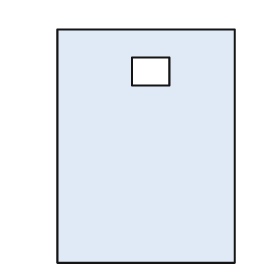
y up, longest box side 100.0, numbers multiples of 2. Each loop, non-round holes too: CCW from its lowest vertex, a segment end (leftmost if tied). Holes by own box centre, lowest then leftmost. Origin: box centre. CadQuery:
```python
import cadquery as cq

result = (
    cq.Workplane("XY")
    .moveTo(-38.0, -50.0)
    .lineTo(38.0, -50.0)
    .lineTo(38.0, 50.0)
    .lineTo(-38.0, 50.0)
    .close()
    .moveTo(-6.0, 26.0)
    .lineTo(10.0, 26.0)
    .lineTo(10.0, 38.0)
    .lineTo(-6.0, 38.0)
    .close()
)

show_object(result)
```